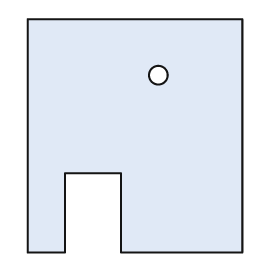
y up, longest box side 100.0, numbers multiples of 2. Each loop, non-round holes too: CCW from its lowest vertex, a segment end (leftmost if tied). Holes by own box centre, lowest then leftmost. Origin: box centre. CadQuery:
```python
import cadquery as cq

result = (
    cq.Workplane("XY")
    .moveTo(-46.0, -50.0)
    .lineTo(-30.0, -50.0)
    .lineTo(-30.0, -16.0)
    .lineTo(-6.0, -16.0)
    .lineTo(-6.0, -50.0)
    .lineTo(46.0, -50.0)
    .lineTo(46.0, 50.0)
    .lineTo(-46.0, 50.0)
    .close()
    .moveTo(10.0, 26.0)
    .circle(4.0)
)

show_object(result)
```